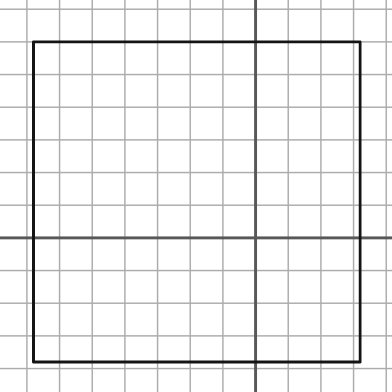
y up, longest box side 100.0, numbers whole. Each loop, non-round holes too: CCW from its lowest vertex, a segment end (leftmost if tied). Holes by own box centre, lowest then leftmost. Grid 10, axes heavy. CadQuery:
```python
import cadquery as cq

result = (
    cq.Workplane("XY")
    .moveTo(-68.0, -38.0)
    .lineTo(32.0, -38.0)
    .lineTo(32.0, 60.0)
    .lineTo(-68.0, 60.0)
    .close()
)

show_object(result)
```